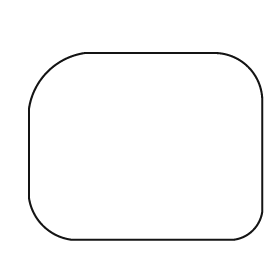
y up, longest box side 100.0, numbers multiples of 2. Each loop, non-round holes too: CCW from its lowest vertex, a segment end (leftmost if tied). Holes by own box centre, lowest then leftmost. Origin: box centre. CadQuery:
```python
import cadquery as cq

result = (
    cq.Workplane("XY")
    .moveTo(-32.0, -40.0)
    .lineTo(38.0, -40.0)
    .threePointArc((46.0, -36.0), (50.0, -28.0))
    .lineTo(50.0, 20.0)
    .threePointArc((44.0, 34.0), (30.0, 40.0))
    .lineTo(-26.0, 40.0)
    .threePointArc((-42.0, 32.0), (-50.0, 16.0))
    .lineTo(-50.0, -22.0)
    .threePointArc((-44.0, -34.0), (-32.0, -40.0))
    .close()
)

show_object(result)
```